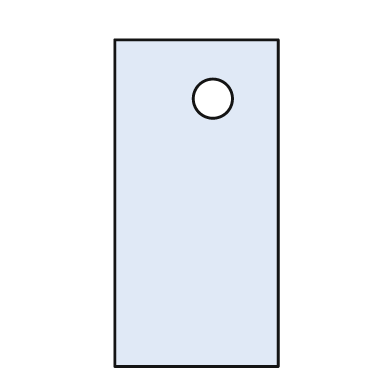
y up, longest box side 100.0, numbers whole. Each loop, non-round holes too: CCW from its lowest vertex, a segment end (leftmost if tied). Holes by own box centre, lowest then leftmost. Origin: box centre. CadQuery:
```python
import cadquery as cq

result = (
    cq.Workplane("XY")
    .moveTo(-25.0, -50.0)
    .lineTo(25.0, -50.0)
    .lineTo(25.0, 50.0)
    .lineTo(-25.0, 50.0)
    .close()
    .moveTo(5.0, 32.0)
    .circle(6.0)
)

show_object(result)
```